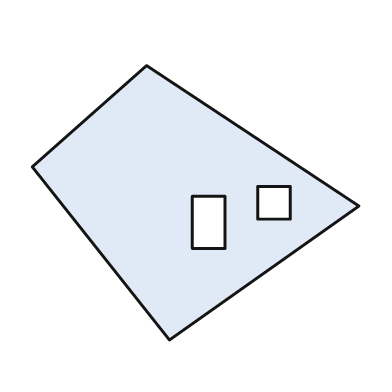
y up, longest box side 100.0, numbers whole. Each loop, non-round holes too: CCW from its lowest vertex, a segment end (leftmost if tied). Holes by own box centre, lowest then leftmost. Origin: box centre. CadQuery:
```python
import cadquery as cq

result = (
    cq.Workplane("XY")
    .moveTo(-8.0, -42.0)
    .lineTo(50.0, -1.0)
    .lineTo(-15.0, 42.0)
    .lineTo(-50.0, 11.0)
    .close()
    .moveTo(-1.0, -14.0)
    .lineTo(9.0, -14.0)
    .lineTo(9.0, 2.0)
    .lineTo(-1.0, 2.0)
    .close()
    .moveTo(19.0, -5.0)
    .lineTo(29.0, -5.0)
    .lineTo(29.0, 5.0)
    .lineTo(19.0, 5.0)
    .close()
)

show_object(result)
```